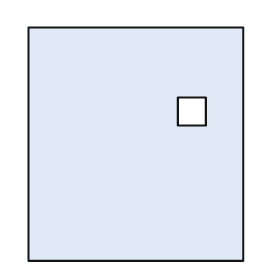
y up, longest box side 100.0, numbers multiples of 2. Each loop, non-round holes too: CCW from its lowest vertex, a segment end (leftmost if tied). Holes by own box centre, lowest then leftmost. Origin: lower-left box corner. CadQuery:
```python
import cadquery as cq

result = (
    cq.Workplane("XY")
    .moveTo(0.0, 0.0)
    .lineTo(92.0, 0.0)
    .lineTo(92.0, 100.0)
    .lineTo(0.0, 100.0)
    .close()
    .moveTo(64.0, 58.0)
    .lineTo(76.0, 58.0)
    .lineTo(76.0, 70.0)
    .lineTo(64.0, 70.0)
    .close()
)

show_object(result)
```